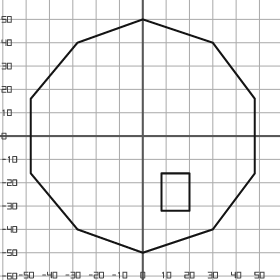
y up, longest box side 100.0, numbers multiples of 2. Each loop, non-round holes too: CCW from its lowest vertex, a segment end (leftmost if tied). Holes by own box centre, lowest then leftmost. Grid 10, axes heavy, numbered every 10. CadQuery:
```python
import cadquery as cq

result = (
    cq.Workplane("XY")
    .moveTo(0.0, -50.0)
    .lineTo(30.0, -40.0)
    .lineTo(48.0, -16.0)
    .lineTo(48.0, 16.0)
    .lineTo(30.0, 40.0)
    .lineTo(0.0, 50.0)
    .lineTo(-28.0, 40.0)
    .lineTo(-48.0, 16.0)
    .lineTo(-48.0, -16.0)
    .lineTo(-28.0, -40.0)
    .close()
    .moveTo(8.0, -32.0)
    .lineTo(20.0, -32.0)
    .lineTo(20.0, -16.0)
    .lineTo(8.0, -16.0)
    .close()
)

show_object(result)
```